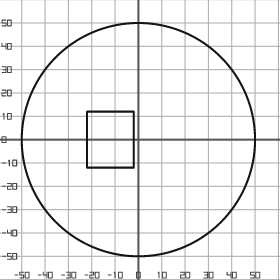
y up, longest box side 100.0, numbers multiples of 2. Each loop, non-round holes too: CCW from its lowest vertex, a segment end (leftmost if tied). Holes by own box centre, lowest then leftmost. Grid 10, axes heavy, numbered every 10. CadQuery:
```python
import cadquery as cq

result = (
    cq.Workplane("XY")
    .moveTo(0.0, 0.0)
    .circle(50.0)
    .moveTo(-22.0, -12.0)
    .lineTo(-2.0, -12.0)
    .lineTo(-2.0, 12.0)
    .lineTo(-22.0, 12.0)
    .close()
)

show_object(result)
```